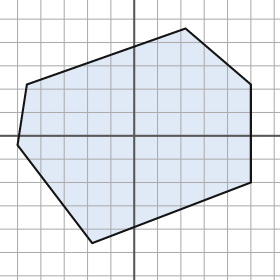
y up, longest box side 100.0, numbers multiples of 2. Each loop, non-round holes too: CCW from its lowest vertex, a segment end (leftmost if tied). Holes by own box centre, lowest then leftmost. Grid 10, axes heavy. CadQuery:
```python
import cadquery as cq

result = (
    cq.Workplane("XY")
    .moveTo(-18.0, -46.0)
    .lineTo(50.0, -20.0)
    .lineTo(50.0, 22.0)
    .lineTo(22.0, 46.0)
    .lineTo(-46.0, 22.0)
    .lineTo(-50.0, -4.0)
    .close()
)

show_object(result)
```